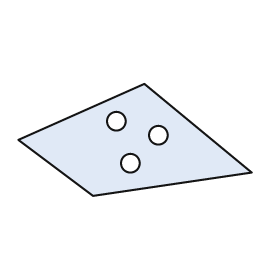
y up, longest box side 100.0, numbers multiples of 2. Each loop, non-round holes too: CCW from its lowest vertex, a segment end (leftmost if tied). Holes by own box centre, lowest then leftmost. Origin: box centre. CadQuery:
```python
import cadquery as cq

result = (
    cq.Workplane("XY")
    .moveTo(-18.0, -24.0)
    .lineTo(50.0, -14.0)
    .lineTo(4.0, 24.0)
    .lineTo(-50.0, 0.0)
    .close()
    .moveTo(-2.0, -10.0)
    .circle(4.0)
    .moveTo(10.0, 2.0)
    .circle(4.0)
    .moveTo(-8.0, 8.0)
    .circle(4.0)
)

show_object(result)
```